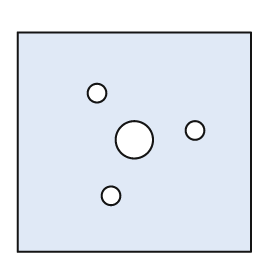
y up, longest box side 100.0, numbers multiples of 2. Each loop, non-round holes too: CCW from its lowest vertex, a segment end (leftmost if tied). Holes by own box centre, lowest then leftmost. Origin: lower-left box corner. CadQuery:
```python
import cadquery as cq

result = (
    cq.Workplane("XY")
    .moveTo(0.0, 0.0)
    .lineTo(100.0, 0.0)
    .lineTo(100.0, 94.0)
    .lineTo(0.0, 94.0)
    .close()
    .moveTo(40.0, 24.0)
    .circle(4.0)
    .moveTo(50.0, 48.0)
    .circle(8.0)
    .moveTo(76.0, 52.0)
    .circle(4.0)
    .moveTo(34.0, 68.0)
    .circle(4.0)
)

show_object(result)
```